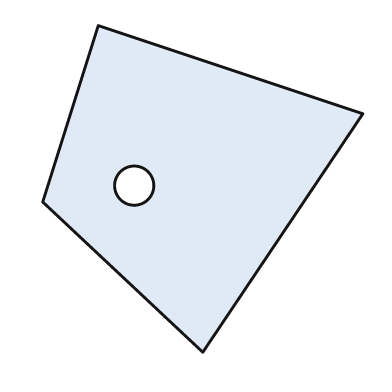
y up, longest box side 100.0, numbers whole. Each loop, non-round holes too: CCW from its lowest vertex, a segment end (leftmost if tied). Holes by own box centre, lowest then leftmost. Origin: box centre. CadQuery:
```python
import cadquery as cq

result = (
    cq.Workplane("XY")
    .moveTo(0.0, -50.0)
    .lineTo(49.0, 23.0)
    .lineTo(-32.0, 50.0)
    .lineTo(-49.0, -4.0)
    .close()
    .moveTo(-21.0, 1.0)
    .circle(6.0)
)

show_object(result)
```